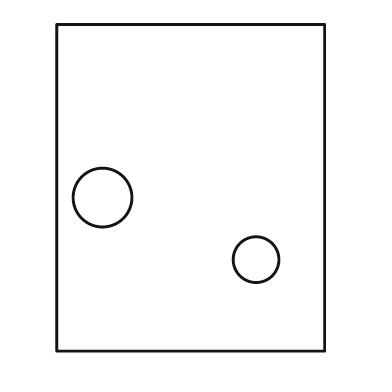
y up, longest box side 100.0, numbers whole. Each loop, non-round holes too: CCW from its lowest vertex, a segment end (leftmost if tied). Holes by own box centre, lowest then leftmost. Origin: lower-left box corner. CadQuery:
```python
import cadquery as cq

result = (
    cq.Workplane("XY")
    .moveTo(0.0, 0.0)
    .lineTo(82.0, 0.0)
    .lineTo(82.0, 100.0)
    .lineTo(0.0, 100.0)
    .close()
    .moveTo(61.0, 28.0)
    .circle(7.0)
    .moveTo(14.0, 47.0)
    .circle(9.0)
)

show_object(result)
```